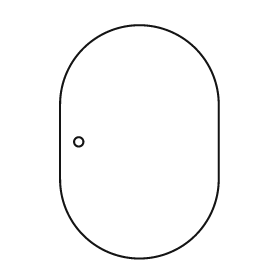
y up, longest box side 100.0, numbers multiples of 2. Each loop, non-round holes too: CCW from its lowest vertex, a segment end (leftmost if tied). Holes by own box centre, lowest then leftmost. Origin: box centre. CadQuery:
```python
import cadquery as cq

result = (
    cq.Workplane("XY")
    .moveTo(-34.0, -16.0)
    .threePointArc((0.0, -50.0), (34.0, -16.0))
    .lineTo(34.0, 16.0)
    .threePointArc((0.0, 50.0), (-34.0, 16.0))
    .close()
    .moveTo(-26.0, 0.0)
    .circle(2.0)
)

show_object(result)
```